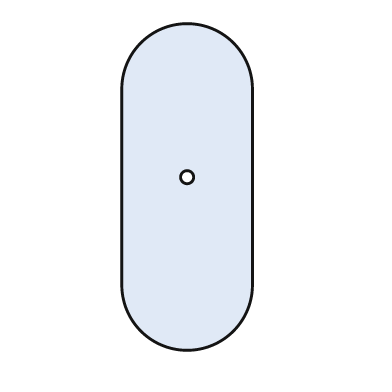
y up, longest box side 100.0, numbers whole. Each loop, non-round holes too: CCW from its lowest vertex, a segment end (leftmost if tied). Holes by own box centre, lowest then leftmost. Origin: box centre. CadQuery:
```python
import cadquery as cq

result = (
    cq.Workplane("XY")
    .moveTo(-20.0, -30.0)
    .threePointArc((0.0, -50.0), (20.0, -30.0))
    .lineTo(20.0, 30.0)
    .threePointArc((0.0, 50.0), (-20.0, 30.0))
    .close()
    .moveTo(0.0, 3.0)
    .circle(2.0)
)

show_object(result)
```